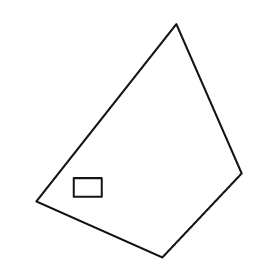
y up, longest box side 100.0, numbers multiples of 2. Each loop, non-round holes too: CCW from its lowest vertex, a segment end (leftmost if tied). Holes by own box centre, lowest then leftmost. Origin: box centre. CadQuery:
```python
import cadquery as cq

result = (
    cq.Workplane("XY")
    .moveTo(10.0, -50.0)
    .lineTo(44.0, -14.0)
    .lineTo(16.0, 50.0)
    .lineTo(-44.0, -26.0)
    .close()
    .moveTo(-28.0, -24.0)
    .lineTo(-16.0, -24.0)
    .lineTo(-16.0, -16.0)
    .lineTo(-28.0, -16.0)
    .close()
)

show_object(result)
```